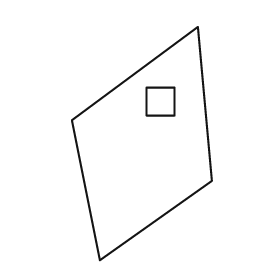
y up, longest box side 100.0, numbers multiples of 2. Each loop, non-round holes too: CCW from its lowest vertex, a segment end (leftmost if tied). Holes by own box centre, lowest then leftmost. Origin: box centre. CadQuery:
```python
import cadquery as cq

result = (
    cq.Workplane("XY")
    .moveTo(-18.0, -50.0)
    .lineTo(30.0, -16.0)
    .lineTo(24.0, 50.0)
    .lineTo(-30.0, 10.0)
    .close()
    .moveTo(2.0, 12.0)
    .lineTo(14.0, 12.0)
    .lineTo(14.0, 24.0)
    .lineTo(2.0, 24.0)
    .close()
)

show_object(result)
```